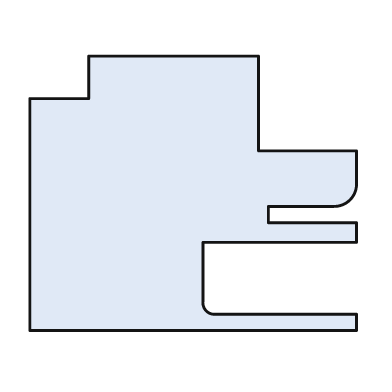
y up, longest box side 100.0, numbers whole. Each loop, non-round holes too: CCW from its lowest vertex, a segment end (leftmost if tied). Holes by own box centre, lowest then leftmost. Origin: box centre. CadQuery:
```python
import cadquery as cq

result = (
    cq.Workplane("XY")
    .moveTo(-50.0, -42.0)
    .lineTo(50.0, -42.0)
    .lineTo(50.0, -37.0)
    .lineTo(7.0, -37.0)
    .threePointArc((4.0, -36.0), (3.0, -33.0))
    .lineTo(3.0, -15.0)
    .lineTo(50.0, -15.0)
    .lineTo(50.0, -9.0)
    .lineTo(23.0, -9.0)
    .lineTo(23.0, -4.0)
    .lineTo(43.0, -4.0)
    .threePointArc((48.0, -2.0), (50.0, 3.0))
    .lineTo(50.0, 13.0)
    .lineTo(20.0, 13.0)
    .lineTo(20.0, 42.0)
    .lineTo(-32.0, 42.0)
    .lineTo(-32.0, 29.0)
    .lineTo(-50.0, 29.0)
    .close()
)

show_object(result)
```